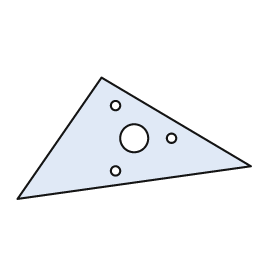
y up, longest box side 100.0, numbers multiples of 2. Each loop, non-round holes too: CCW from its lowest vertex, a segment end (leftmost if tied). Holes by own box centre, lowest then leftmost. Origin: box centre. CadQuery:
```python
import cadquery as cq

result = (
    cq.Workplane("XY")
    .moveTo(-50.0, -26.0)
    .lineTo(50.0, -12.0)
    .lineTo(-14.0, 26.0)
    .close()
    .moveTo(-8.0, -14.0)
    .circle(2.0)
    .moveTo(0.0, 0.0)
    .circle(6.0)
    .moveTo(16.0, 0.0)
    .circle(2.0)
    .moveTo(-8.0, 14.0)
    .circle(2.0)
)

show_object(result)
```